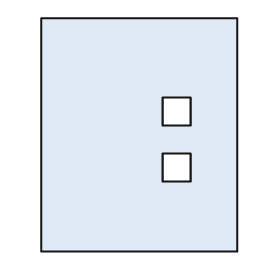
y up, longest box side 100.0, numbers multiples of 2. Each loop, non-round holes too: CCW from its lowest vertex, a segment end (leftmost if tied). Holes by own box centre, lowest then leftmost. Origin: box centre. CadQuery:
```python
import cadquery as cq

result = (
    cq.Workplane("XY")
    .moveTo(-42.0, -50.0)
    .lineTo(42.0, -50.0)
    .lineTo(42.0, 50.0)
    .lineTo(-42.0, 50.0)
    .close()
    .moveTo(10.0, -20.0)
    .lineTo(22.0, -20.0)
    .lineTo(22.0, -8.0)
    .lineTo(10.0, -8.0)
    .close()
    .moveTo(10.0, 4.0)
    .lineTo(22.0, 4.0)
    .lineTo(22.0, 16.0)
    .lineTo(10.0, 16.0)
    .close()
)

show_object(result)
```